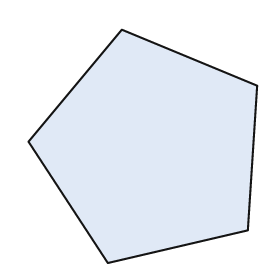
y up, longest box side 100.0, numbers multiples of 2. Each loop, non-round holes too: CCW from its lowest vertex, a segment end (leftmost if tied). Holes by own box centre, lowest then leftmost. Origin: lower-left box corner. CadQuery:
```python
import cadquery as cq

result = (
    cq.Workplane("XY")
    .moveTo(34.0, 0.0)
    .lineTo(94.0, 14.0)
    .lineTo(98.0, 76.0)
    .lineTo(40.0, 100.0)
    .lineTo(0.0, 52.0)
    .close()
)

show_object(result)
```